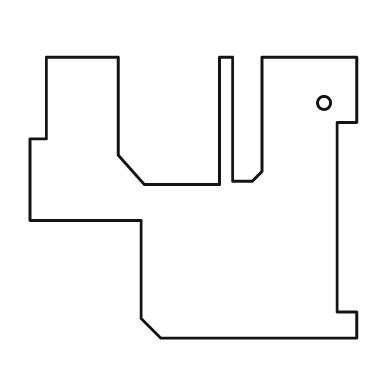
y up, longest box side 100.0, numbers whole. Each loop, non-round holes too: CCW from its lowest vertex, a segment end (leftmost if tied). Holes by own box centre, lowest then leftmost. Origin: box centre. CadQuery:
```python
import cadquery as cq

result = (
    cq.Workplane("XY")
    .moveTo(-10.0, -43.0)
    .lineTo(50.0, -43.0)
    .lineTo(50.0, -35.0)
    .lineTo(44.0, -35.0)
    .lineTo(44.0, 23.0)
    .lineTo(50.0, 23.0)
    .lineTo(50.0, 43.0)
    .lineTo(21.0, 43.0)
    .lineTo(21.0, 8.0)
    .lineTo(18.0, 5.0)
    .lineTo(12.0, 5.0)
    .lineTo(12.0, 43.0)
    .lineTo(8.0, 43.0)
    .lineTo(8.0, 4.0)
    .lineTo(-15.0, 4.0)
    .lineTo(-23.0, 13.0)
    .lineTo(-23.0, 43.0)
    .lineTo(-45.0, 43.0)
    .lineTo(-45.0, 18.0)
    .lineTo(-50.0, 18.0)
    .lineTo(-50.0, -7.0)
    .lineTo(-16.0, -7.0)
    .lineTo(-16.0, -37.0)
    .close()
    .moveTo(40.0, 29.0)
    .circle(2.0)
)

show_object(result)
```